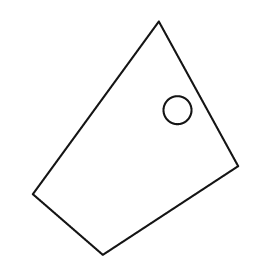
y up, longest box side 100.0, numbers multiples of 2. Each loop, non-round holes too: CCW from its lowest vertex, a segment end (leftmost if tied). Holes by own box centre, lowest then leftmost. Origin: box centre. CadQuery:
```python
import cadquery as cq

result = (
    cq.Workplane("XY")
    .moveTo(-14.0, -50.0)
    .lineTo(44.0, -12.0)
    .lineTo(10.0, 50.0)
    .lineTo(-44.0, -24.0)
    .close()
    .moveTo(18.0, 12.0)
    .circle(6.0)
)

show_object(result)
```